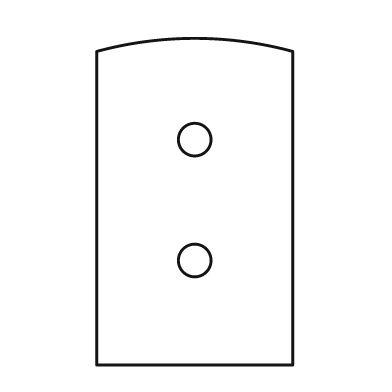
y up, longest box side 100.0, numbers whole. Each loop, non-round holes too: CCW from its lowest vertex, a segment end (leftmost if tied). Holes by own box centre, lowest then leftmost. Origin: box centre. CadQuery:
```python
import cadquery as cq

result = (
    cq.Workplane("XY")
    .moveTo(-30.0, -50.0)
    .lineTo(30.0, -50.0)
    .lineTo(30.0, 46.0)
    .threePointArc((0.0, 50.0), (-30.0, 46.0))
    .close()
    .moveTo(0.0, -18.0)
    .circle(5.0)
    .moveTo(0.0, 19.0)
    .circle(5.0)
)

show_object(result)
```